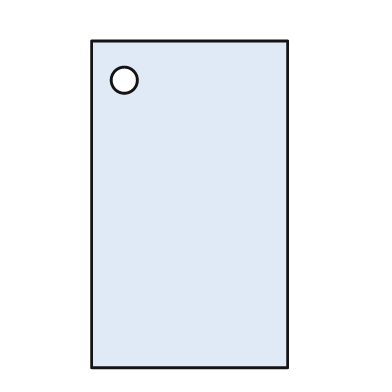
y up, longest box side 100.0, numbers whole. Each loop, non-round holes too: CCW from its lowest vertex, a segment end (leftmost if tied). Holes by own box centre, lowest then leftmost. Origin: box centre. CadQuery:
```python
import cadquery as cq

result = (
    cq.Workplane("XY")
    .moveTo(-30.0, -50.0)
    .lineTo(30.0, -50.0)
    .lineTo(30.0, 50.0)
    .lineTo(-30.0, 50.0)
    .close()
    .moveTo(-20.0, 38.0)
    .circle(4.0)
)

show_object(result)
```